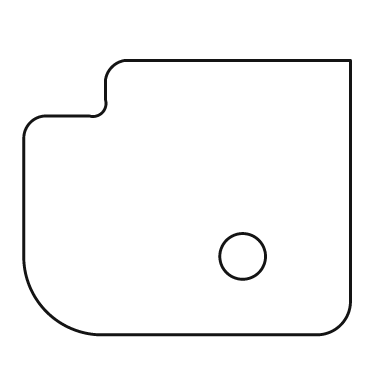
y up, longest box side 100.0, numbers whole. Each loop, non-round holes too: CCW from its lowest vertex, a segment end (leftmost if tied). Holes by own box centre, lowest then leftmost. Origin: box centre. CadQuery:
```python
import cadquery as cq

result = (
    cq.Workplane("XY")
    .moveTo(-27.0, -42.0)
    .lineTo(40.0, -42.0)
    .threePointArc((47.0, -39.0), (50.0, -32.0))
    .lineTo(50.0, 42.0)
    .lineTo(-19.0, 42.0)
    .threePointArc((-23.0, 40.0), (-25.0, 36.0))
    .lineTo(-25.0, 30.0)
    .threePointArc((-26.0, 26.0), (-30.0, 25.0))
    .lineTo(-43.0, 25.0)
    .threePointArc((-48.0, 23.0), (-50.0, 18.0))
    .lineTo(-50.0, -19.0)
    .threePointArc((-43.0, -35.0), (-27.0, -42.0))
    .close()
    .moveTo(17.0, -18.0)
    .circle(7.0)
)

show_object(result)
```